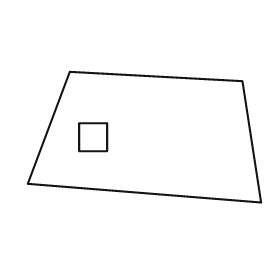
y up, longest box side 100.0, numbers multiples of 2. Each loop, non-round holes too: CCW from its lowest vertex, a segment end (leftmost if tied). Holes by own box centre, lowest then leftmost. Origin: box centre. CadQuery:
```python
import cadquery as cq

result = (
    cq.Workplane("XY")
    .moveTo(50.0, -28.0)
    .lineTo(42.0, 24.0)
    .lineTo(-32.0, 28.0)
    .lineTo(-50.0, -20.0)
    .close()
    .moveTo(-28.0, -6.0)
    .lineTo(-16.0, -6.0)
    .lineTo(-16.0, 6.0)
    .lineTo(-28.0, 6.0)
    .close()
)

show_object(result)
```